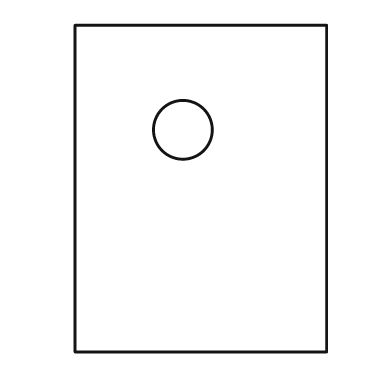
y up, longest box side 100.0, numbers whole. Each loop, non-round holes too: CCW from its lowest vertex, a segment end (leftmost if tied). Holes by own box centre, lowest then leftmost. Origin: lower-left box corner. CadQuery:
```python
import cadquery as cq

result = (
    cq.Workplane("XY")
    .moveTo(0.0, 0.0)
    .lineTo(77.0, 0.0)
    .lineTo(77.0, 100.0)
    .lineTo(0.0, 100.0)
    .close()
    .moveTo(33.0, 68.0)
    .circle(9.0)
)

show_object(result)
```